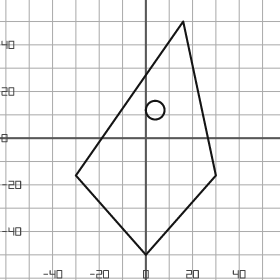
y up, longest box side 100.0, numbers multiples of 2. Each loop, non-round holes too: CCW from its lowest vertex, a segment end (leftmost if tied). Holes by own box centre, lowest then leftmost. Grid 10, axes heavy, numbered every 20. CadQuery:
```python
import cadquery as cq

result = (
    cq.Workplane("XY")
    .moveTo(0.0, -50.0)
    .lineTo(30.0, -16.0)
    .lineTo(16.0, 50.0)
    .lineTo(-30.0, -16.0)
    .close()
    .moveTo(4.0, 12.0)
    .circle(4.0)
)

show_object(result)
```